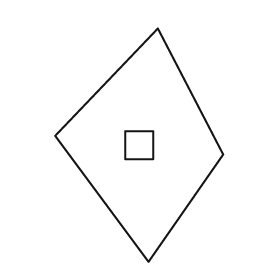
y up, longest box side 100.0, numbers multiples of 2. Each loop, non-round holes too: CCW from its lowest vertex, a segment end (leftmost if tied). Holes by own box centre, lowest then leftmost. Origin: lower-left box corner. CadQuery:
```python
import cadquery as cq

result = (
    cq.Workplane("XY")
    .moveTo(40.0, 0.0)
    .lineTo(72.0, 46.0)
    .lineTo(44.0, 100.0)
    .lineTo(0.0, 54.0)
    .close()
    .moveTo(30.0, 44.0)
    .lineTo(42.0, 44.0)
    .lineTo(42.0, 56.0)
    .lineTo(30.0, 56.0)
    .close()
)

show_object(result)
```